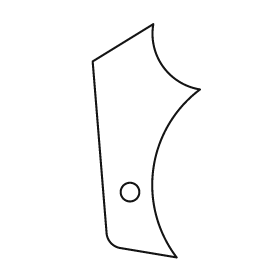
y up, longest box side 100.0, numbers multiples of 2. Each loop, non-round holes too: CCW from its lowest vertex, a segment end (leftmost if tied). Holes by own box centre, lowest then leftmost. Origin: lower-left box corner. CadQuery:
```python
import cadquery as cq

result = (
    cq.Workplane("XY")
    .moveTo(36.0, 0.0)
    .threePointArc((26.0, 38.0), (46.0, 72.0))
    .threePointArc((30.0, 82.0), (26.0, 100.0))
    .lineTo(0.0, 84.0)
    .lineTo(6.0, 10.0)
    .threePointArc((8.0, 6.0), (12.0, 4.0))
    .close()
    .moveTo(16.0, 28.0)
    .circle(4.0)
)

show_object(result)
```